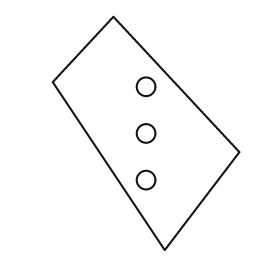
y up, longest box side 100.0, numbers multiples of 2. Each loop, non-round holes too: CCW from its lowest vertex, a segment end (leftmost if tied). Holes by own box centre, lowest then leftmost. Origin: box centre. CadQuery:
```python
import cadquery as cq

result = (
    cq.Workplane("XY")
    .moveTo(8.0, -50.0)
    .lineTo(40.0, -8.0)
    .lineTo(-14.0, 50.0)
    .lineTo(-40.0, 22.0)
    .close()
    .moveTo(0.0, -20.0)
    .circle(4.0)
    .moveTo(0.0, 0.0)
    .circle(4.0)
    .moveTo(0.0, 20.0)
    .circle(4.0)
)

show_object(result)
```